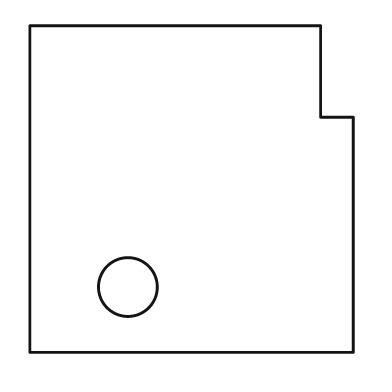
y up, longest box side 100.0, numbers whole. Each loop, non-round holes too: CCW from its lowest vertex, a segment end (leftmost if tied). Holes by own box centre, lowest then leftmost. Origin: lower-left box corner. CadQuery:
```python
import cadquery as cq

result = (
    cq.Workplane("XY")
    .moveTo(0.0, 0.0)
    .lineTo(99.0, 0.0)
    .lineTo(99.0, 72.0)
    .lineTo(89.0, 72.0)
    .lineTo(89.0, 100.0)
    .lineTo(0.0, 100.0)
    .close()
    .moveTo(30.0, 20.0)
    .circle(9.0)
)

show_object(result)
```